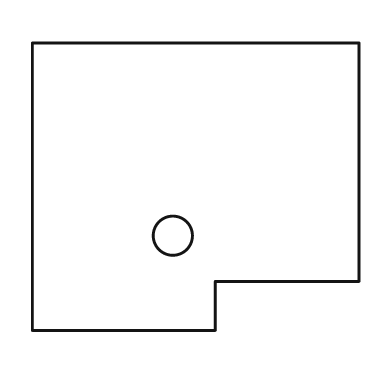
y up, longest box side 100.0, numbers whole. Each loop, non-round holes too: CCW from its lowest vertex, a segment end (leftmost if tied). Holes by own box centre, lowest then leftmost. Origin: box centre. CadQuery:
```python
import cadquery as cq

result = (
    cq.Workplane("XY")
    .moveTo(-50.0, -44.0)
    .lineTo(6.0, -44.0)
    .lineTo(6.0, -29.0)
    .lineTo(50.0, -29.0)
    .lineTo(50.0, 44.0)
    .lineTo(-50.0, 44.0)
    .close()
    .moveTo(-7.0, -15.0)
    .circle(6.0)
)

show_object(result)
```